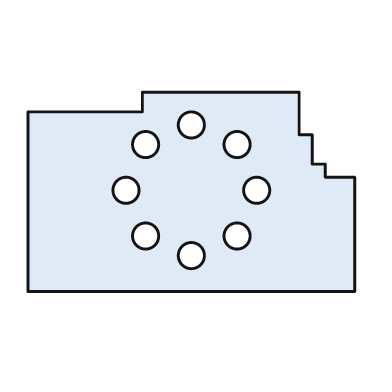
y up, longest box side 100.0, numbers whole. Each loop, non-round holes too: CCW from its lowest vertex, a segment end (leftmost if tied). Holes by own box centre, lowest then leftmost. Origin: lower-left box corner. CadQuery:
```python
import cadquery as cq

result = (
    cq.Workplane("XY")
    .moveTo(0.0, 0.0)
    .lineTo(100.0, 0.0)
    .lineTo(100.0, 35.0)
    .lineTo(91.0, 35.0)
    .lineTo(91.0, 39.0)
    .lineTo(87.0, 39.0)
    .lineTo(87.0, 48.0)
    .lineTo(83.0, 48.0)
    .lineTo(83.0, 61.0)
    .lineTo(35.0, 61.0)
    .lineTo(35.0, 55.0)
    .lineTo(0.0, 55.0)
    .close()
    .moveTo(50.0, 11.0)
    .circle(4.0)
    .moveTo(36.0, 17.0)
    .circle(4.0)
    .moveTo(64.0, 17.0)
    .circle(4.0)
    .moveTo(30.0, 31.0)
    .circle(4.0)
    .moveTo(70.0, 31.0)
    .circle(4.0)
    .moveTo(36.0, 45.0)
    .circle(4.0)
    .moveTo(64.0, 45.0)
    .circle(4.0)
    .moveTo(50.0, 51.0)
    .circle(4.0)
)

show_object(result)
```